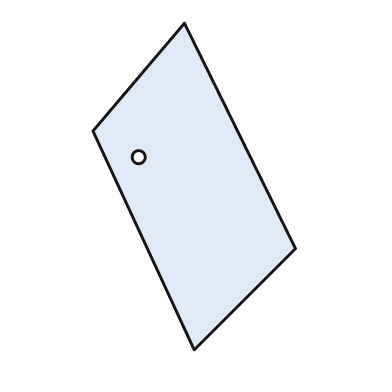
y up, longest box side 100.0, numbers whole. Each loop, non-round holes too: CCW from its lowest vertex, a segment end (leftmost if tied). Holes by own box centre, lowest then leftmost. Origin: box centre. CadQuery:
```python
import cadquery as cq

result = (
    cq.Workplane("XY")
    .moveTo(0.0, -50.0)
    .lineTo(31.0, -19.0)
    .lineTo(-3.0, 50.0)
    .lineTo(-31.0, 17.0)
    .close()
    .moveTo(-17.0, 9.0)
    .circle(2.0)
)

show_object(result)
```